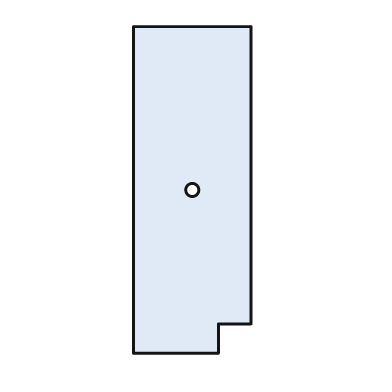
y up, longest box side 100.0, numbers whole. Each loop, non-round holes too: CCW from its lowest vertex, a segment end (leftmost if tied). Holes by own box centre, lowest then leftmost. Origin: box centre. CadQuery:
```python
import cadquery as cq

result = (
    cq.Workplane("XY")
    .moveTo(-18.0, -50.0)
    .lineTo(8.0, -50.0)
    .lineTo(8.0, -41.0)
    .lineTo(18.0, -41.0)
    .lineTo(18.0, 50.0)
    .lineTo(-18.0, 50.0)
    .close()
    .moveTo(0.0, 0.0)
    .circle(2.0)
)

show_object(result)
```